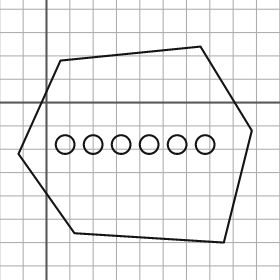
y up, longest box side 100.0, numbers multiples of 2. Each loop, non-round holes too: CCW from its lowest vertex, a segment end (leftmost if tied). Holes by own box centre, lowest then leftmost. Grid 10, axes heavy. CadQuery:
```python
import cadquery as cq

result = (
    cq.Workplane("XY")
    .moveTo(76.0, -60.0)
    .lineTo(88.0, -12.0)
    .lineTo(66.0, 24.0)
    .lineTo(6.0, 18.0)
    .lineTo(-12.0, -22.0)
    .lineTo(12.0, -56.0)
    .close()
    .moveTo(8.0, -18.0)
    .circle(4.0)
    .moveTo(20.0, -18.0)
    .circle(4.0)
    .moveTo(32.0, -18.0)
    .circle(4.0)
    .moveTo(44.0, -18.0)
    .circle(4.0)
    .moveTo(56.0, -18.0)
    .circle(4.0)
    .moveTo(68.0, -18.0)
    .circle(4.0)
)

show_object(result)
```